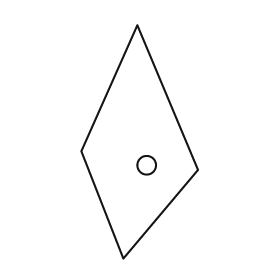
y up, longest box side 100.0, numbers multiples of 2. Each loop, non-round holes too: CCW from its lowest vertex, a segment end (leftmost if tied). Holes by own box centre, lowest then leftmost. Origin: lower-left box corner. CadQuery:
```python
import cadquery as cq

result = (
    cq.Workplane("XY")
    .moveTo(18.0, 0.0)
    .lineTo(50.0, 38.0)
    .lineTo(24.0, 100.0)
    .lineTo(0.0, 46.0)
    .close()
    .moveTo(28.0, 40.0)
    .circle(4.0)
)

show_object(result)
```